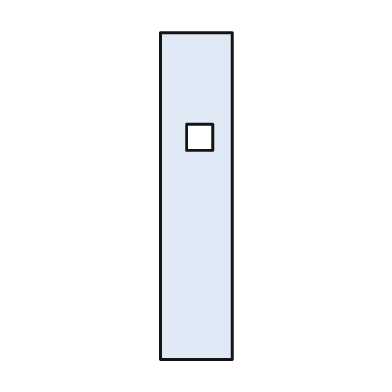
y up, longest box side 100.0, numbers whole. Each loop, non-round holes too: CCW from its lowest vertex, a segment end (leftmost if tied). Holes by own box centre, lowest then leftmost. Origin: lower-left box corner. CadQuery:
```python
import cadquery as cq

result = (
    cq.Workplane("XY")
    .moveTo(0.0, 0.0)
    .lineTo(22.0, 0.0)
    .lineTo(22.0, 100.0)
    .lineTo(0.0, 100.0)
    .close()
    .moveTo(8.0, 64.0)
    .lineTo(16.0, 64.0)
    .lineTo(16.0, 72.0)
    .lineTo(8.0, 72.0)
    .close()
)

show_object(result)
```